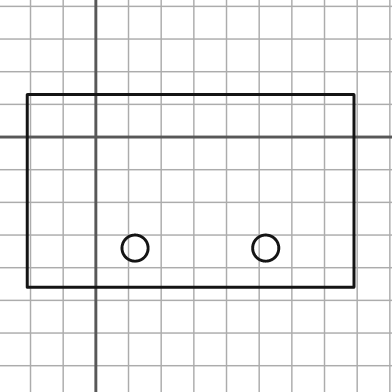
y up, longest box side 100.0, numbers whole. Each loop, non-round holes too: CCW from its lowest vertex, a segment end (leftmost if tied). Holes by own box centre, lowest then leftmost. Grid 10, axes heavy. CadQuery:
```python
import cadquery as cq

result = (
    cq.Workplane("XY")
    .moveTo(-21.0, -46.0)
    .lineTo(79.0, -46.0)
    .lineTo(79.0, 13.0)
    .lineTo(-21.0, 13.0)
    .close()
    .moveTo(12.0, -34.0)
    .circle(4.0)
    .moveTo(52.0, -34.0)
    .circle(4.0)
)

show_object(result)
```